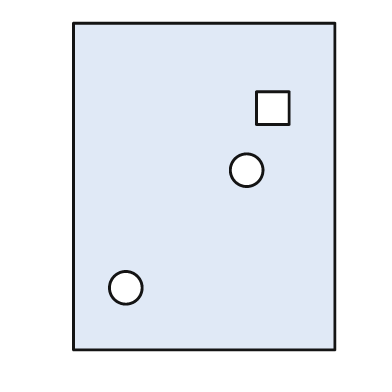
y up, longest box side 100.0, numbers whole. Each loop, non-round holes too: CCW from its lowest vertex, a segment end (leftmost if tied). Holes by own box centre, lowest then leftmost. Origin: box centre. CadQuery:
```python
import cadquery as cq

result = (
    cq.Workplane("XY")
    .moveTo(-40.0, -50.0)
    .lineTo(40.0, -50.0)
    .lineTo(40.0, 50.0)
    .lineTo(-40.0, 50.0)
    .close()
    .moveTo(-24.0, -31.0)
    .circle(5.0)
    .moveTo(13.0, 5.0)
    .circle(5.0)
    .moveTo(16.0, 19.0)
    .lineTo(26.0, 19.0)
    .lineTo(26.0, 29.0)
    .lineTo(16.0, 29.0)
    .close()
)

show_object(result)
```